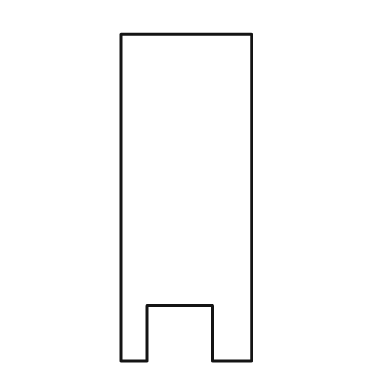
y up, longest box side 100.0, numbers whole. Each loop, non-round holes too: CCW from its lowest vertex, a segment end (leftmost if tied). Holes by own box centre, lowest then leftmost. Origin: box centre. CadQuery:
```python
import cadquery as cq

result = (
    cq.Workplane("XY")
    .moveTo(-20.0, -50.0)
    .lineTo(-12.0, -50.0)
    .lineTo(-12.0, -33.0)
    .lineTo(8.0, -33.0)
    .lineTo(8.0, -50.0)
    .lineTo(20.0, -50.0)
    .lineTo(20.0, 50.0)
    .lineTo(-20.0, 50.0)
    .close()
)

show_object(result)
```